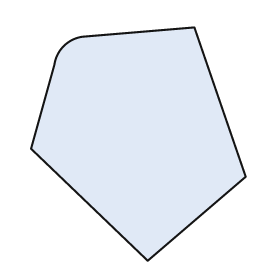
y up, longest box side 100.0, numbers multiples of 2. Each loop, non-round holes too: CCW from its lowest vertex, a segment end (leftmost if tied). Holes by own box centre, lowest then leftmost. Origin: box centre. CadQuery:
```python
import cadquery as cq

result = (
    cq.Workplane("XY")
    .moveTo(4.0, -50.0)
    .lineTo(46.0, -14.0)
    .lineTo(24.0, 50.0)
    .lineTo(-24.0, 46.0)
    .threePointArc((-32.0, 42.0), (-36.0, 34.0))
    .lineTo(-46.0, -2.0)
    .close()
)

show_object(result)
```